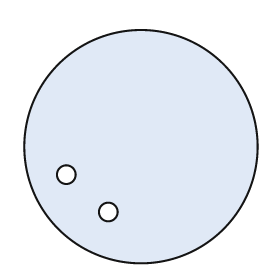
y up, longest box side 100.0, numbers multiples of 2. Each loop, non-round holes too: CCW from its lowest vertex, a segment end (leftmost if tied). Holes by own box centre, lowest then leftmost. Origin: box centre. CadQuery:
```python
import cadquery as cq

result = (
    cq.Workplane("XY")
    .moveTo(0.0, 0.0)
    .circle(50.0)
    .moveTo(-14.0, -28.0)
    .circle(4.0)
    .moveTo(-32.0, -12.0)
    .circle(4.0)
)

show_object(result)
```